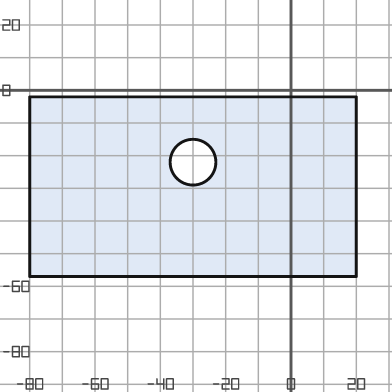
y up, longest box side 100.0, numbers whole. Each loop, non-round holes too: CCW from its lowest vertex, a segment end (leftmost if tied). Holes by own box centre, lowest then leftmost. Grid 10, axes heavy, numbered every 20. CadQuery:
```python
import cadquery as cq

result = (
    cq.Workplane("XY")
    .moveTo(-80.0, -57.0)
    .lineTo(20.0, -57.0)
    .lineTo(20.0, -2.0)
    .lineTo(-80.0, -2.0)
    .close()
    .moveTo(-30.0, -22.0)
    .circle(7.0)
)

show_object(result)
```